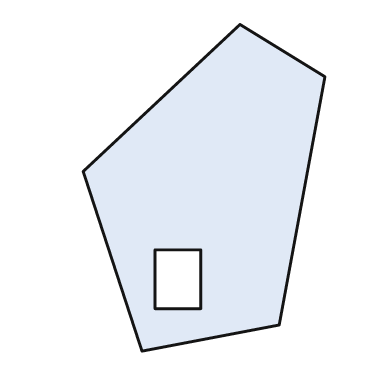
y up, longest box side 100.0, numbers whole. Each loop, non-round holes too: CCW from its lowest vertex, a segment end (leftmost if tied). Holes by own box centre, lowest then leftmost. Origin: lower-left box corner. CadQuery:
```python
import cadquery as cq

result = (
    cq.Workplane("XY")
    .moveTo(18.0, 0.0)
    .lineTo(60.0, 8.0)
    .lineTo(74.0, 84.0)
    .lineTo(48.0, 100.0)
    .lineTo(0.0, 55.0)
    .close()
    .moveTo(22.0, 13.0)
    .lineTo(36.0, 13.0)
    .lineTo(36.0, 31.0)
    .lineTo(22.0, 31.0)
    .close()
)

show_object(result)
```